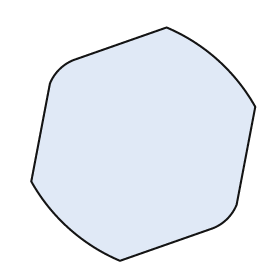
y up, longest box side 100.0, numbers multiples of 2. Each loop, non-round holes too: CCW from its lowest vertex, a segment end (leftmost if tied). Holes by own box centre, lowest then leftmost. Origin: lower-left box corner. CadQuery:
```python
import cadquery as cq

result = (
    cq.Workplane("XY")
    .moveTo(38.0, 0.0)
    .lineTo(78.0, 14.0)
    .threePointArc((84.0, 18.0), (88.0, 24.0))
    .lineTo(96.0, 66.0)
    .threePointArc((80.0, 86.0), (58.0, 100.0))
    .lineTo(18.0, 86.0)
    .threePointArc((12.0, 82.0), (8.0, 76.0))
    .lineTo(0.0, 34.0)
    .threePointArc((16.0, 14.0), (38.0, 0.0))
    .close()
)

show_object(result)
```